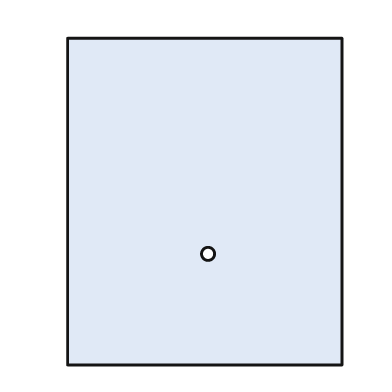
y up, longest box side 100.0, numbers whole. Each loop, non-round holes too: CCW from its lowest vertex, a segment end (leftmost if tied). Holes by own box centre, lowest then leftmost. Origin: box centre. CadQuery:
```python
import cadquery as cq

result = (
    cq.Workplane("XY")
    .moveTo(-42.0, -50.0)
    .lineTo(42.0, -50.0)
    .lineTo(42.0, 50.0)
    .lineTo(-42.0, 50.0)
    .close()
    .moveTo(1.0, -16.0)
    .circle(2.0)
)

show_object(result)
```